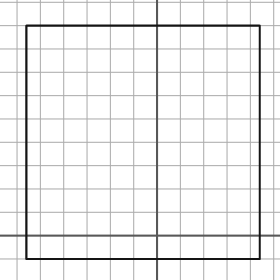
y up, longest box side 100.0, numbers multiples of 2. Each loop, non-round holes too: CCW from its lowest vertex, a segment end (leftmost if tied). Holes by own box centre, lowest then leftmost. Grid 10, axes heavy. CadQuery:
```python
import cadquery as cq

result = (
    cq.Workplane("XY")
    .moveTo(-56.0, -10.0)
    .lineTo(44.0, -10.0)
    .lineTo(44.0, 90.0)
    .lineTo(-56.0, 90.0)
    .close()
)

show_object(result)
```